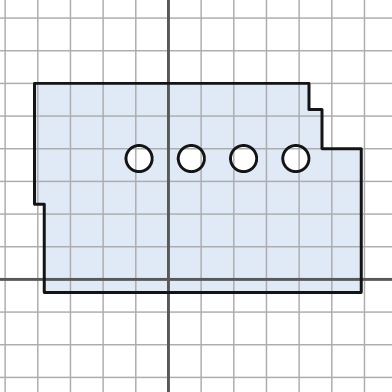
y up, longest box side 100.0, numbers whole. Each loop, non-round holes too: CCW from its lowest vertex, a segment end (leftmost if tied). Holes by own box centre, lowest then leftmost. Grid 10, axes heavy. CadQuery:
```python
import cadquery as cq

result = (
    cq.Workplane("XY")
    .moveTo(-38.0, -4.0)
    .lineTo(59.0, -4.0)
    .lineTo(59.0, 40.0)
    .lineTo(47.0, 40.0)
    .lineTo(47.0, 52.0)
    .lineTo(43.0, 52.0)
    .lineTo(43.0, 60.0)
    .lineTo(-41.0, 60.0)
    .lineTo(-41.0, 23.0)
    .lineTo(-38.0, 23.0)
    .close()
    .moveTo(-9.0, 37.0)
    .circle(4.0)
    .moveTo(7.0, 37.0)
    .circle(4.0)
    .moveTo(23.0, 37.0)
    .circle(4.0)
    .moveTo(39.0, 37.0)
    .circle(4.0)
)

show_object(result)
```